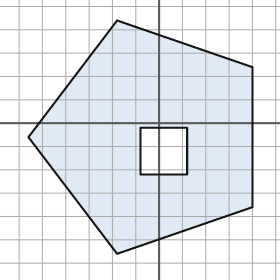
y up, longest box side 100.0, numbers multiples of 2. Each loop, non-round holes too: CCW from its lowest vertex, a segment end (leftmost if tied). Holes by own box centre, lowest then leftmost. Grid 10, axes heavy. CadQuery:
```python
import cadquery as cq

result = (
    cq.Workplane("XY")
    .moveTo(-18.0, -56.0)
    .lineTo(40.0, -36.0)
    .lineTo(40.0, 24.0)
    .lineTo(-18.0, 44.0)
    .lineTo(-56.0, -6.0)
    .close()
    .moveTo(-8.0, -22.0)
    .lineTo(12.0, -22.0)
    .lineTo(12.0, -2.0)
    .lineTo(-8.0, -2.0)
    .close()
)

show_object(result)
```